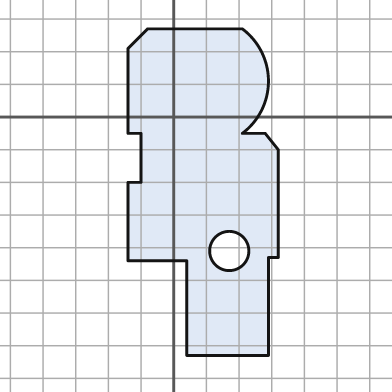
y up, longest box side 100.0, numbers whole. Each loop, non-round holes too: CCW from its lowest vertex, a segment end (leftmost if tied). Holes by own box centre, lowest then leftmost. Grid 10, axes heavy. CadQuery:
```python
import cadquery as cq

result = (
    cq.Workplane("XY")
    .moveTo(4.0, -73.0)
    .lineTo(29.0, -73.0)
    .lineTo(29.0, -43.0)
    .lineTo(32.0, -43.0)
    .lineTo(32.0, -10.0)
    .lineTo(28.0, -5.0)
    .lineTo(21.0, -5.0)
    .threePointArc((29.0, 11.0), (21.0, 27.0))
    .lineTo(-8.0, 27.0)
    .lineTo(-14.0, 21.0)
    .lineTo(-14.0, -5.0)
    .lineTo(-10.0, -5.0)
    .lineTo(-10.0, -20.0)
    .lineTo(-14.0, -20.0)
    .lineTo(-14.0, -44.0)
    .lineTo(4.0, -44.0)
    .close()
    .moveTo(17.0, -41.0)
    .circle(6.0)
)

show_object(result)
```